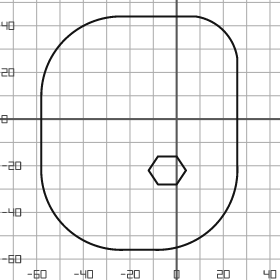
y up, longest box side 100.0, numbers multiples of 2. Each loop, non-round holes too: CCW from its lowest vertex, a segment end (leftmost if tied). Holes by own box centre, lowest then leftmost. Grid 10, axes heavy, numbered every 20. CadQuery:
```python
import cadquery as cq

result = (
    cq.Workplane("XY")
    .moveTo(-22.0, -56.0)
    .lineTo(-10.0, -56.0)
    .threePointArc((16.0, -46.0), (26.0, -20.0))
    .lineTo(26.0, 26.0)
    .threePointArc((20.0, 38.0), (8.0, 44.0))
    .lineTo(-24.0, 44.0)
    .threePointArc((-48.0, 34.0), (-58.0, 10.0))
    .lineTo(-58.0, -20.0)
    .threePointArc((-48.0, -46.0), (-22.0, -56.0))
    .close()
    .moveTo(-8.0, -28.0)
    .lineTo(0.0, -28.0)
    .lineTo(4.0, -22.0)
    .lineTo(0.0, -16.0)
    .lineTo(-8.0, -16.0)
    .lineTo(-12.0, -22.0)
    .close()
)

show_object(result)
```